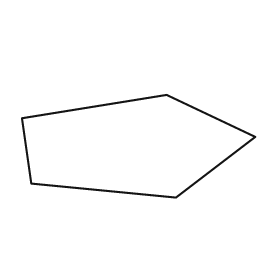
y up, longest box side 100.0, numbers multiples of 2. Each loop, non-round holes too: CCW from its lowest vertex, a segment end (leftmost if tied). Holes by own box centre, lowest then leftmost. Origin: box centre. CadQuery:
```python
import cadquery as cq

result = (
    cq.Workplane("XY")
    .moveTo(16.0, -22.0)
    .lineTo(50.0, 4.0)
    .lineTo(12.0, 22.0)
    .lineTo(-50.0, 12.0)
    .lineTo(-46.0, -16.0)
    .close()
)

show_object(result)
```